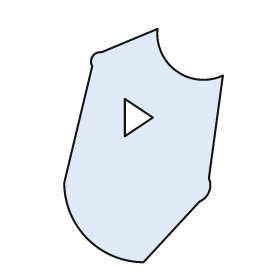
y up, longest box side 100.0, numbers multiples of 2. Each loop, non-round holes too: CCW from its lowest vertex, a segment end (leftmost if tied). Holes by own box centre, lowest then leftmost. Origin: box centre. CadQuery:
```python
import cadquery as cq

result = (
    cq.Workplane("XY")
    .moveTo(0.0, -50.0)
    .lineTo(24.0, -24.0)
    .threePointArc((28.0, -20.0), (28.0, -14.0))
    .lineTo(34.0, 30.0)
    .threePointArc((14.0, 32.0), (6.0, 50.0))
    .lineTo(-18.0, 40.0)
    .threePointArc((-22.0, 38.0), (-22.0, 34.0))
    .lineTo(-34.0, -16.0)
    .threePointArc((-24.0, -40.0), (0.0, -50.0))
    .close()
    .moveTo(-8.0, 4.0)
    .lineTo(4.0, 12.0)
    .lineTo(-8.0, 20.0)
    .close()
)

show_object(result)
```